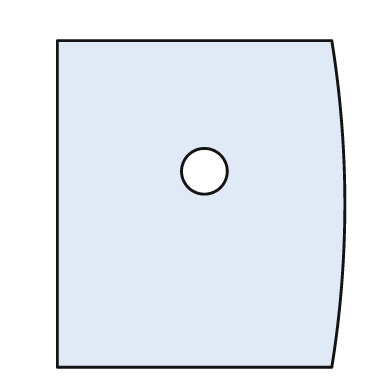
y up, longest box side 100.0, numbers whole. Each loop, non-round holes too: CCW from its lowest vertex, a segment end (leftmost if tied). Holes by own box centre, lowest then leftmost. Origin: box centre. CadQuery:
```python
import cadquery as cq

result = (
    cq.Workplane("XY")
    .moveTo(-44.0, -50.0)
    .lineTo(40.0, -50.0)
    .threePointArc((44.0, 0.0), (40.0, 50.0))
    .lineTo(-44.0, 50.0)
    .close()
    .moveTo(1.0, 10.0)
    .circle(7.0)
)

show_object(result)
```